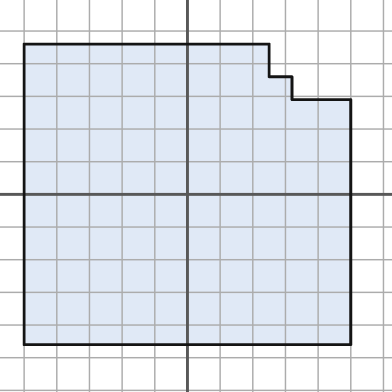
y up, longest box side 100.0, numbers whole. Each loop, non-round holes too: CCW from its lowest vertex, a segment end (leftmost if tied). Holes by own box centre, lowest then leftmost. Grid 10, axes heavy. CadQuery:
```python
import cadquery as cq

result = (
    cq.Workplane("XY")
    .moveTo(-50.0, -46.0)
    .lineTo(50.0, -46.0)
    .lineTo(50.0, 29.0)
    .lineTo(32.0, 29.0)
    .lineTo(32.0, 36.0)
    .lineTo(25.0, 36.0)
    .lineTo(25.0, 46.0)
    .lineTo(-50.0, 46.0)
    .close()
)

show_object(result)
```